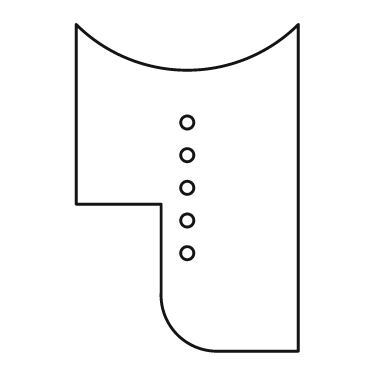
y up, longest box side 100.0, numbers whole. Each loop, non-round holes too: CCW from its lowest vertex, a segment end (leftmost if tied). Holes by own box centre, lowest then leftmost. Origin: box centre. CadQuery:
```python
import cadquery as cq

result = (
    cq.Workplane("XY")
    .moveTo(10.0, -50.0)
    .lineTo(34.0, -50.0)
    .lineTo(34.0, 50.0)
    .threePointArc((0.0, 36.0), (-34.0, 50.0))
    .lineTo(-34.0, -5.0)
    .lineTo(-8.0, -5.0)
    .lineTo(-8.0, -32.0)
    .threePointArc((-3.0, -45.0), (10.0, -50.0))
    .close()
    .moveTo(0.0, -20.0)
    .circle(2.0)
    .moveTo(0.0, -10.0)
    .circle(2.0)
    .moveTo(0.0, 0.0)
    .circle(2.0)
    .moveTo(0.0, 10.0)
    .circle(2.0)
    .moveTo(0.0, 20.0)
    .circle(2.0)
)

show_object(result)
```